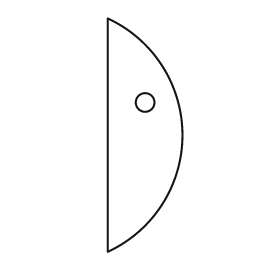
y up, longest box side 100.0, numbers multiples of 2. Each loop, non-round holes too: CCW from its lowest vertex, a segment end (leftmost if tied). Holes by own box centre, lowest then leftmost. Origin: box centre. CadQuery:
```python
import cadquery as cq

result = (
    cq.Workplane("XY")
    .moveTo(-16.0, -50.0)
    .threePointArc((16.0, 0.0), (-16.0, 50.0))
    .close()
    .moveTo(0.0, 14.0)
    .circle(4.0)
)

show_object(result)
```